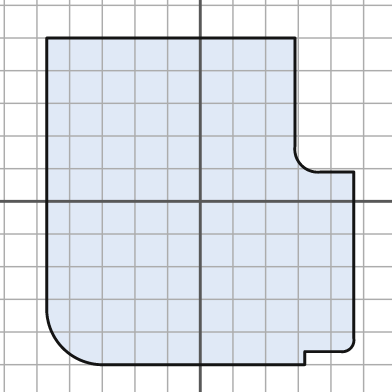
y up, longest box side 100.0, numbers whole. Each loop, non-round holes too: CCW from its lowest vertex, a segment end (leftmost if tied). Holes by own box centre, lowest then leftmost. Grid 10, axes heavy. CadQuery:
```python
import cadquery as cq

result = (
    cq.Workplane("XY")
    .moveTo(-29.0, -50.0)
    .lineTo(32.0, -50.0)
    .lineTo(32.0, -46.0)
    .lineTo(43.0, -46.0)
    .threePointArc((46.0, -45.0), (47.0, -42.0))
    .lineTo(47.0, 9.0)
    .lineTo(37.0, 9.0)
    .threePointArc((31.0, 11.0), (29.0, 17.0))
    .lineTo(29.0, 50.0)
    .lineTo(-47.0, 50.0)
    .lineTo(-47.0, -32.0)
    .threePointArc((-42.0, -45.0), (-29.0, -50.0))
    .close()
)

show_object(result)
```